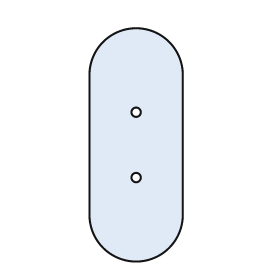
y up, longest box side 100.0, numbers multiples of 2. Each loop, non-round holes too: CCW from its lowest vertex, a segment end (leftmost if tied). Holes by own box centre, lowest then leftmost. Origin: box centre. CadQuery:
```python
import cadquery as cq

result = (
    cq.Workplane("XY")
    .moveTo(-20.0, -30.0)
    .threePointArc((0.0, -50.0), (20.0, -30.0))
    .lineTo(20.0, 30.0)
    .threePointArc((0.0, 50.0), (-20.0, 30.0))
    .close()
    .moveTo(0.0, -14.0)
    .circle(2.0)
    .moveTo(0.0, 14.0)
    .circle(2.0)
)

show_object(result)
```